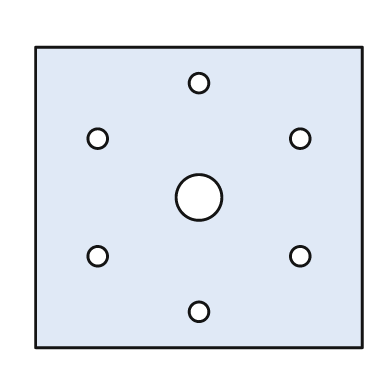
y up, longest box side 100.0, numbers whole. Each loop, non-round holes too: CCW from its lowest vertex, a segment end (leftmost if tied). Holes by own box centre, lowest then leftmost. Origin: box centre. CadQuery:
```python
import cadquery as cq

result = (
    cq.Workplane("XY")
    .moveTo(-50.0, -46.0)
    .lineTo(50.0, -46.0)
    .lineTo(50.0, 46.0)
    .lineTo(-50.0, 46.0)
    .close()
    .moveTo(0.0, -35.0)
    .circle(3.0)
    .moveTo(-31.0, -18.0)
    .circle(3.0)
    .moveTo(31.0, -18.0)
    .circle(3.0)
    .moveTo(0.0, 0.0)
    .circle(7.0)
    .moveTo(-31.0, 18.0)
    .circle(3.0)
    .moveTo(31.0, 18.0)
    .circle(3.0)
    .moveTo(0.0, 35.0)
    .circle(3.0)
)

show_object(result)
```